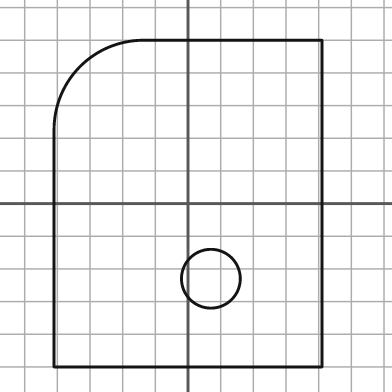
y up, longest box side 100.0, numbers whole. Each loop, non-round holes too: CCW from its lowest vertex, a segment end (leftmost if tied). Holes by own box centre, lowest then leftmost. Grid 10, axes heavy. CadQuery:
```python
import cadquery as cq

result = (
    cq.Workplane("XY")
    .moveTo(-41.0, -50.0)
    .lineTo(41.0, -50.0)
    .lineTo(41.0, 50.0)
    .lineTo(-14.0, 50.0)
    .threePointArc((-33.0, 42.0), (-41.0, 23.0))
    .close()
    .moveTo(7.0, -23.0)
    .circle(9.0)
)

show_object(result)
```